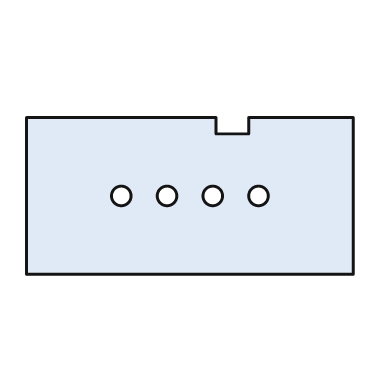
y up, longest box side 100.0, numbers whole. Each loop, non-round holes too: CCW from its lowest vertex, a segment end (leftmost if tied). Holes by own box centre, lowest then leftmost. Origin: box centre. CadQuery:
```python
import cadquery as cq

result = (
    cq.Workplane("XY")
    .moveTo(-50.0, -24.0)
    .lineTo(50.0, -24.0)
    .lineTo(50.0, 24.0)
    .lineTo(18.0, 24.0)
    .lineTo(18.0, 19.0)
    .lineTo(8.0, 19.0)
    .lineTo(8.0, 24.0)
    .lineTo(-50.0, 24.0)
    .close()
    .moveTo(-21.0, 0.0)
    .circle(3.0)
    .moveTo(-7.0, 0.0)
    .circle(3.0)
    .moveTo(7.0, 0.0)
    .circle(3.0)
    .moveTo(21.0, 0.0)
    .circle(3.0)
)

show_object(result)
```